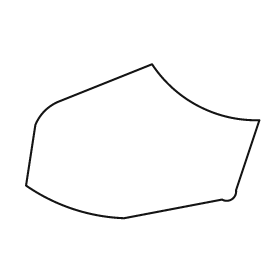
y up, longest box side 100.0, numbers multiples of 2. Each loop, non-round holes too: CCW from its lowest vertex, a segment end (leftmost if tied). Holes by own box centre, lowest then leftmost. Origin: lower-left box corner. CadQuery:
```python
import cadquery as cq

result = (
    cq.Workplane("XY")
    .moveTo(42.0, 0.0)
    .lineTo(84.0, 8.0)
    .threePointArc((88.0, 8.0), (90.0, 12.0))
    .lineTo(100.0, 42.0)
    .threePointArc((74.0, 48.0), (54.0, 66.0))
    .lineTo(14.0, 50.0)
    .threePointArc((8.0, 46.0), (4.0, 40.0))
    .lineTo(0.0, 14.0)
    .threePointArc((20.0, 4.0), (42.0, 0.0))
    .close()
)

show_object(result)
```